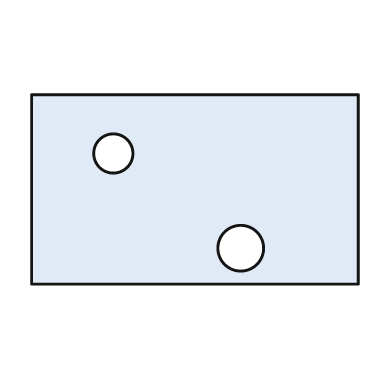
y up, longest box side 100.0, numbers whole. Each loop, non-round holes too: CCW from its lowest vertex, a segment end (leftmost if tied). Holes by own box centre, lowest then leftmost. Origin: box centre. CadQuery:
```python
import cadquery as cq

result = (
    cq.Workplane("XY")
    .moveTo(-50.0, -29.0)
    .lineTo(50.0, -29.0)
    .lineTo(50.0, 29.0)
    .lineTo(-50.0, 29.0)
    .close()
    .moveTo(14.0, -18.0)
    .circle(7.0)
    .moveTo(-25.0, 11.0)
    .circle(6.0)
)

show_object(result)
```